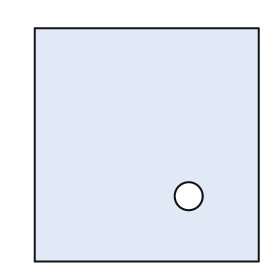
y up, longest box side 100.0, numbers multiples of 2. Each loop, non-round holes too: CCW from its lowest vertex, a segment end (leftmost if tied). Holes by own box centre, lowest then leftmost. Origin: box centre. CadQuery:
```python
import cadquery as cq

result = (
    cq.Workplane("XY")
    .moveTo(-48.0, -50.0)
    .lineTo(48.0, -50.0)
    .lineTo(48.0, 50.0)
    .lineTo(-48.0, 50.0)
    .close()
    .moveTo(18.0, -22.0)
    .circle(6.0)
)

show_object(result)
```